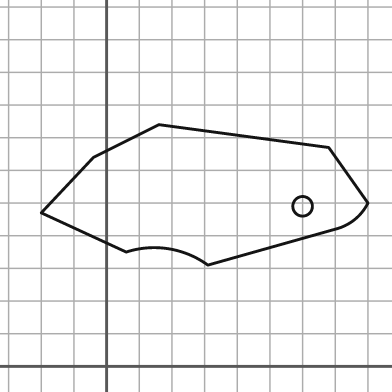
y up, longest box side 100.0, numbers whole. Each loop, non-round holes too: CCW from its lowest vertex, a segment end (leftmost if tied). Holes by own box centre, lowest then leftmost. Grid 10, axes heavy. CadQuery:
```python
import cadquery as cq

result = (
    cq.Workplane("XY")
    .moveTo(31.0, 31.0)
    .lineTo(70.0, 42.0)
    .threePointArc((76.0, 45.0), (80.0, 50.0))
    .lineTo(68.0, 67.0)
    .lineTo(16.0, 74.0)
    .lineTo(-4.0, 64.0)
    .lineTo(-20.0, 47.0)
    .lineTo(6.0, 35.0)
    .threePointArc((19.0, 36.0), (31.0, 31.0))
    .close()
    .moveTo(60.0, 49.0)
    .circle(3.0)
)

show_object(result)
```